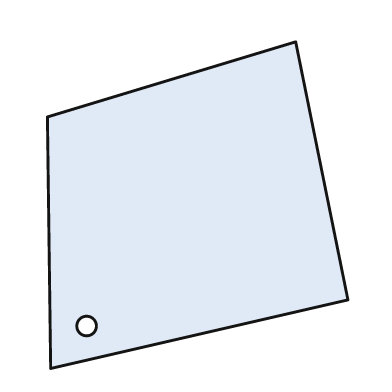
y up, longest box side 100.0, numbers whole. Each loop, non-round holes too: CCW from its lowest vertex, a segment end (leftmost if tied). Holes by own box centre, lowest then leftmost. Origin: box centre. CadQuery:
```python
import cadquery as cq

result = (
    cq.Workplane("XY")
    .moveTo(-45.0, -50.0)
    .lineTo(46.0, -29.0)
    .lineTo(30.0, 50.0)
    .lineTo(-46.0, 27.0)
    .close()
    .moveTo(-34.0, -37.0)
    .circle(3.0)
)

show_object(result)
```